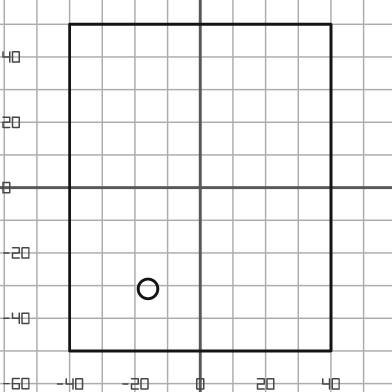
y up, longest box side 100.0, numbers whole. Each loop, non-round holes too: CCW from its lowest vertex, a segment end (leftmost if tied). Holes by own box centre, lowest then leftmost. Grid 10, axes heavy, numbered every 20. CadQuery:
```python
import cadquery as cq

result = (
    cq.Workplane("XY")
    .moveTo(-40.0, -50.0)
    .lineTo(40.0, -50.0)
    .lineTo(40.0, 50.0)
    .lineTo(-40.0, 50.0)
    .close()
    .moveTo(-16.0, -31.0)
    .circle(3.0)
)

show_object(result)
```